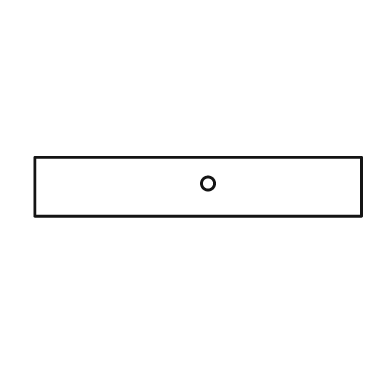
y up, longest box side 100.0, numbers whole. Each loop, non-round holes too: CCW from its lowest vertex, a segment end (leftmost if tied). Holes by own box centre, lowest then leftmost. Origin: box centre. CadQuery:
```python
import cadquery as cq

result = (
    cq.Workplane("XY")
    .moveTo(-50.0, -9.0)
    .lineTo(50.0, -9.0)
    .lineTo(50.0, 9.0)
    .lineTo(-50.0, 9.0)
    .close()
    .moveTo(3.0, 1.0)
    .circle(2.0)
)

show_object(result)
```